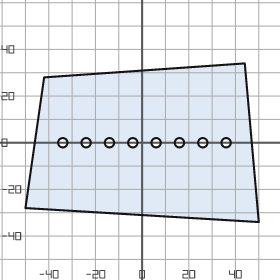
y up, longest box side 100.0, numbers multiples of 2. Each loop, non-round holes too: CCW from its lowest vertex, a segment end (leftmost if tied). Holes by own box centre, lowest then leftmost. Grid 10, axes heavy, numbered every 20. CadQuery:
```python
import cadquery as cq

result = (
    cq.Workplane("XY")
    .moveTo(50.0, -34.0)
    .lineTo(44.0, 34.0)
    .lineTo(-42.0, 28.0)
    .lineTo(-50.0, -28.0)
    .close()
    .moveTo(-34.0, 0.0)
    .circle(2.0)
    .moveTo(-24.0, 0.0)
    .circle(2.0)
    .moveTo(-14.0, 0.0)
    .circle(2.0)
    .moveTo(-4.0, 0.0)
    .circle(2.0)
    .moveTo(6.0, 0.0)
    .circle(2.0)
    .moveTo(16.0, 0.0)
    .circle(2.0)
    .moveTo(26.0, 0.0)
    .circle(2.0)
    .moveTo(36.0, 0.0)
    .circle(2.0)
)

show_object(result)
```